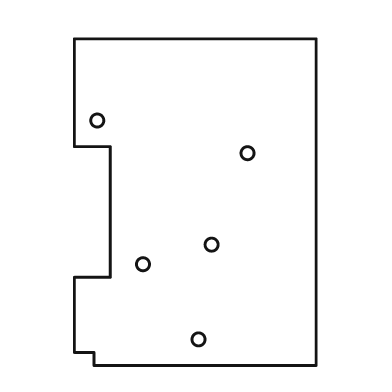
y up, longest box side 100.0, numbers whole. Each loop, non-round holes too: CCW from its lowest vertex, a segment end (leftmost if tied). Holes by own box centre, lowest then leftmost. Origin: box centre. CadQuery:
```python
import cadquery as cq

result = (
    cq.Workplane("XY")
    .moveTo(-31.0, -50.0)
    .lineTo(37.0, -50.0)
    .lineTo(37.0, 50.0)
    .lineTo(-37.0, 50.0)
    .lineTo(-37.0, 17.0)
    .lineTo(-26.0, 17.0)
    .lineTo(-26.0, -23.0)
    .lineTo(-37.0, -23.0)
    .lineTo(-37.0, -46.0)
    .lineTo(-31.0, -46.0)
    .close()
    .moveTo(1.0, -42.0)
    .circle(2.0)
    .moveTo(-16.0, -19.0)
    .circle(2.0)
    .moveTo(5.0, -13.0)
    .circle(2.0)
    .moveTo(16.0, 15.0)
    .circle(2.0)
    .moveTo(-30.0, 25.0)
    .circle(2.0)
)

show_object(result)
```